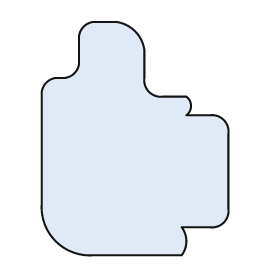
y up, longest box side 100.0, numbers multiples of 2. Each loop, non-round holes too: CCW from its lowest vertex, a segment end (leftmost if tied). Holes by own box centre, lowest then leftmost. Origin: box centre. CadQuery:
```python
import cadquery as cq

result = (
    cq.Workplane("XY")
    .moveTo(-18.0, -50.0)
    .lineTo(20.0, -50.0)
    .threePointArc((22.0, -44.0), (20.0, -38.0))
    .lineTo(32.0, -38.0)
    .threePointArc((38.0, -36.0), (40.0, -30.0))
    .lineTo(40.0, 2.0)
    .threePointArc((38.0, 8.0), (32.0, 10.0))
    .lineTo(22.0, 10.0)
    .threePointArc((24.0, 14.0), (22.0, 18.0))
    .lineTo(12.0, 18.0)
    .threePointArc((6.0, 20.0), (4.0, 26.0))
    .lineTo(4.0, 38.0)
    .threePointArc((0.0, 46.0), (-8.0, 50.0))
    .lineTo(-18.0, 50.0)
    .threePointArc((-22.0, 48.0), (-24.0, 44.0))
    .lineTo(-24.0, 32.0)
    .threePointArc((-26.0, 28.0), (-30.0, 26.0))
    .lineTo(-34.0, 26.0)
    .threePointArc((-38.0, 24.0), (-40.0, 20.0))
    .lineTo(-40.0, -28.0)
    .threePointArc((-34.0, -44.0), (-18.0, -50.0))
    .close()
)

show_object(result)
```